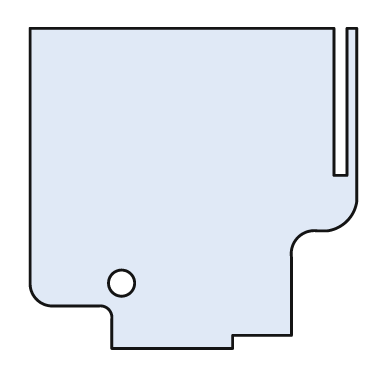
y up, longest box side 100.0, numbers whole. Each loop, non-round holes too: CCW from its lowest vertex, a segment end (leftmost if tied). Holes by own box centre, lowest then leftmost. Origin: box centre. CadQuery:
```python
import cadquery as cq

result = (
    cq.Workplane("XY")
    .moveTo(-25.0, -49.0)
    .lineTo(12.0, -49.0)
    .lineTo(12.0, -45.0)
    .lineTo(30.0, -45.0)
    .lineTo(30.0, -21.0)
    .threePointArc((32.0, -15.0), (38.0, -13.0))
    .lineTo(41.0, -13.0)
    .threePointArc((47.0, -10.0), (50.0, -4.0))
    .lineTo(50.0, 49.0)
    .lineTo(47.0, 49.0)
    .lineTo(47.0, 4.0)
    .lineTo(43.0, 4.0)
    .lineTo(43.0, 49.0)
    .lineTo(-50.0, 49.0)
    .lineTo(-50.0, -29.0)
    .threePointArc((-48.0, -34.0), (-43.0, -36.0))
    .lineTo(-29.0, -36.0)
    .threePointArc((-26.0, -37.0), (-25.0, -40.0))
    .close()
    .moveTo(-22.0, -29.0)
    .circle(4.0)
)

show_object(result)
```